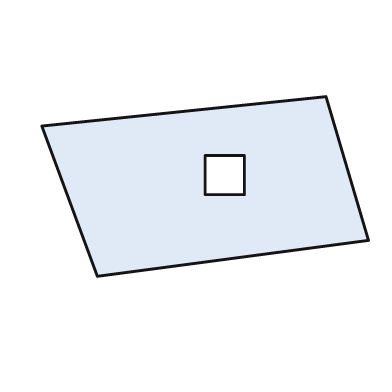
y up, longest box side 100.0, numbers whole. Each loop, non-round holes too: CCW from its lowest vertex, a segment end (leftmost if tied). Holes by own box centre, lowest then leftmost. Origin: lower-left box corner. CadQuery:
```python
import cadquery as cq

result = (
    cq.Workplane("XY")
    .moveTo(17.0, 0.0)
    .lineTo(100.0, 11.0)
    .lineTo(87.0, 55.0)
    .lineTo(0.0, 46.0)
    .close()
    .moveTo(50.0, 25.0)
    .lineTo(62.0, 25.0)
    .lineTo(62.0, 37.0)
    .lineTo(50.0, 37.0)
    .close()
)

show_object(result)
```